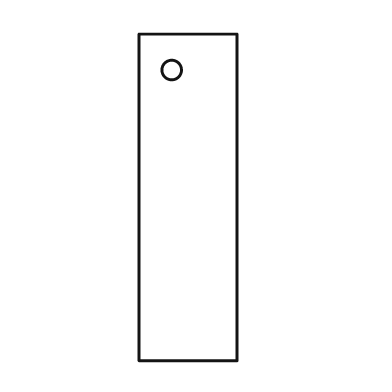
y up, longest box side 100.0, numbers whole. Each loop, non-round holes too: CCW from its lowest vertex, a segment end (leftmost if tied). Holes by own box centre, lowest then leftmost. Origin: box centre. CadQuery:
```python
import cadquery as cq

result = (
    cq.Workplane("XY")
    .moveTo(-15.0, -50.0)
    .lineTo(15.0, -50.0)
    .lineTo(15.0, 50.0)
    .lineTo(-15.0, 50.0)
    .close()
    .moveTo(-5.0, 39.0)
    .circle(3.0)
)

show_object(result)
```